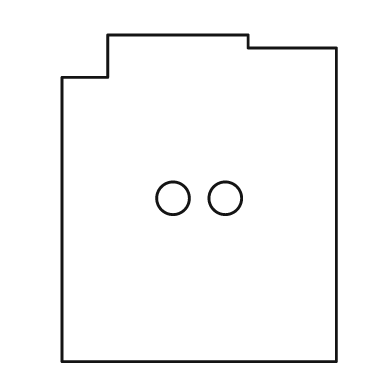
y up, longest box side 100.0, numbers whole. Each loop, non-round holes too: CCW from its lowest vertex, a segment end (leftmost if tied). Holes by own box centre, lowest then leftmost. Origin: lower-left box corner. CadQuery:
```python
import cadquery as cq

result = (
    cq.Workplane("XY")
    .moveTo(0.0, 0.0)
    .lineTo(84.0, 0.0)
    .lineTo(84.0, 96.0)
    .lineTo(57.0, 96.0)
    .lineTo(57.0, 100.0)
    .lineTo(14.0, 100.0)
    .lineTo(14.0, 87.0)
    .lineTo(0.0, 87.0)
    .close()
    .moveTo(34.0, 50.0)
    .circle(5.0)
    .moveTo(50.0, 50.0)
    .circle(5.0)
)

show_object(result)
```